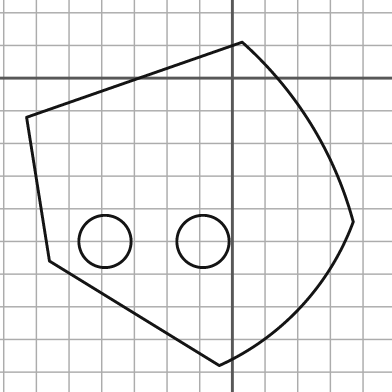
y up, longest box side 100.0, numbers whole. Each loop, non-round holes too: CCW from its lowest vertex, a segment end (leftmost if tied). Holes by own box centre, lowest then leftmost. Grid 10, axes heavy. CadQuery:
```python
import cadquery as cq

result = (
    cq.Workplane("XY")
    .moveTo(-4.0, -88.0)
    .threePointArc((21.0, -70.0), (37.0, -44.0))
    .threePointArc((24.0, -14.0), (3.0, 11.0))
    .lineTo(-63.0, -12.0)
    .lineTo(-56.0, -56.0)
    .close()
    .moveTo(-39.0, -50.0)
    .circle(8.0)
    .moveTo(-9.0, -50.0)
    .circle(8.0)
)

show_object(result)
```